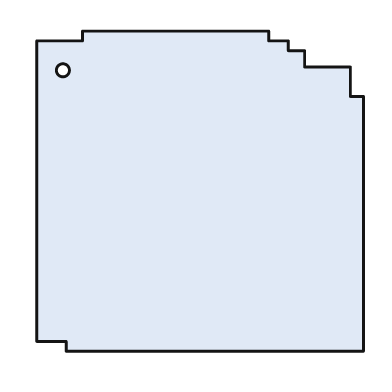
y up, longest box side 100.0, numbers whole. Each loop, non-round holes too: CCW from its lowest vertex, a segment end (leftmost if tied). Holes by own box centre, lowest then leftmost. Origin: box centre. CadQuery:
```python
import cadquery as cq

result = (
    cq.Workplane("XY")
    .moveTo(-41.0, -49.0)
    .lineTo(50.0, -49.0)
    .lineTo(50.0, 29.0)
    .lineTo(46.0, 29.0)
    .lineTo(46.0, 38.0)
    .lineTo(32.0, 38.0)
    .lineTo(32.0, 43.0)
    .lineTo(27.0, 43.0)
    .lineTo(27.0, 46.0)
    .lineTo(21.0, 46.0)
    .lineTo(21.0, 49.0)
    .lineTo(-36.0, 49.0)
    .lineTo(-36.0, 46.0)
    .lineTo(-50.0, 46.0)
    .lineTo(-50.0, -46.0)
    .lineTo(-41.0, -46.0)
    .close()
    .moveTo(-42.0, 37.0)
    .circle(2.0)
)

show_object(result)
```